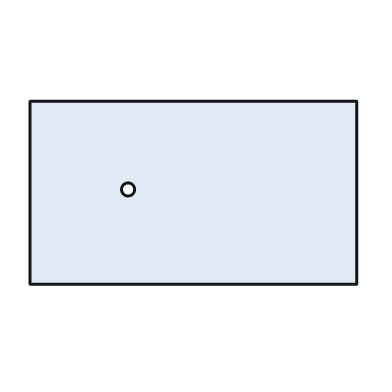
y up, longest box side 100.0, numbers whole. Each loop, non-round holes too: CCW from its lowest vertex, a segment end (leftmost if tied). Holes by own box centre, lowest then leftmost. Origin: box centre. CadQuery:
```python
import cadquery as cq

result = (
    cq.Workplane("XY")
    .moveTo(-50.0, -28.0)
    .lineTo(50.0, -28.0)
    .lineTo(50.0, 28.0)
    .lineTo(-50.0, 28.0)
    .close()
    .moveTo(-20.0, 1.0)
    .circle(2.0)
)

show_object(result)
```